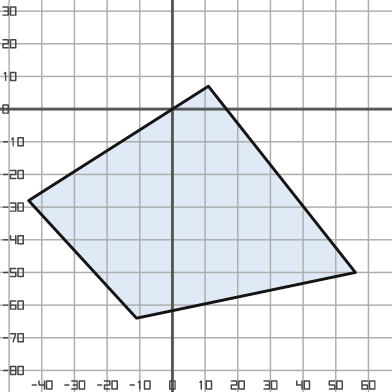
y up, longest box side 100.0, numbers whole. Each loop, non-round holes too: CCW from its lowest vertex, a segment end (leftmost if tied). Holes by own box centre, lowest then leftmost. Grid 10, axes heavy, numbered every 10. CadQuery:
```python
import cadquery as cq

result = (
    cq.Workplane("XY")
    .moveTo(-11.0, -64.0)
    .lineTo(56.0, -50.0)
    .lineTo(11.0, 7.0)
    .lineTo(-44.0, -28.0)
    .close()
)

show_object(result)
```